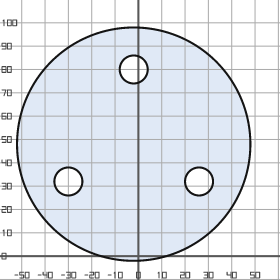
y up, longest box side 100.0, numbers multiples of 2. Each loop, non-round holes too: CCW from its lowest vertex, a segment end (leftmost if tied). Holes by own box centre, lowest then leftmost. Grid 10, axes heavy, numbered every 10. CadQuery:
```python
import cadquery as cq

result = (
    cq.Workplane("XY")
    .moveTo(-2.0, 48.0)
    .circle(50.0)
    .moveTo(-30.0, 32.0)
    .circle(6.0)
    .moveTo(26.0, 32.0)
    .circle(6.0)
    .moveTo(-2.0, 80.0)
    .circle(6.0)
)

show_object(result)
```